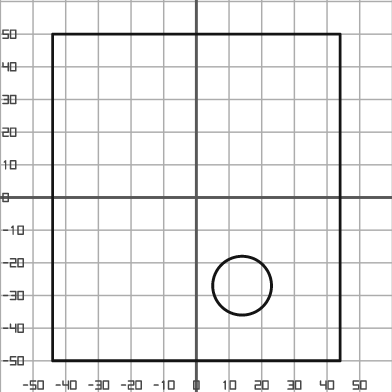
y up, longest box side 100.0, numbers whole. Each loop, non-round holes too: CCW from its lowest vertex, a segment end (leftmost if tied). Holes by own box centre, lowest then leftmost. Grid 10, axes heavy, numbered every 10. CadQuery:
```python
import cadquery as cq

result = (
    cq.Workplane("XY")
    .moveTo(-44.0, -50.0)
    .lineTo(44.0, -50.0)
    .lineTo(44.0, 50.0)
    .lineTo(-44.0, 50.0)
    .close()
    .moveTo(14.0, -27.0)
    .circle(9.0)
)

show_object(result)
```